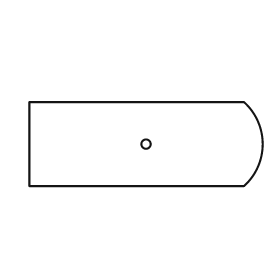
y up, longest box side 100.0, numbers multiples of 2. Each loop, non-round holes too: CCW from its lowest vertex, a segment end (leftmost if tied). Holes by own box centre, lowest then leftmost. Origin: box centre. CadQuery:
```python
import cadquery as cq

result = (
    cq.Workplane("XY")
    .moveTo(-50.0, -18.0)
    .lineTo(42.0, -18.0)
    .threePointArc((50.0, 0.0), (42.0, 18.0))
    .lineTo(-50.0, 18.0)
    .close()
    .moveTo(0.0, 0.0)
    .circle(2.0)
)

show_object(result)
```